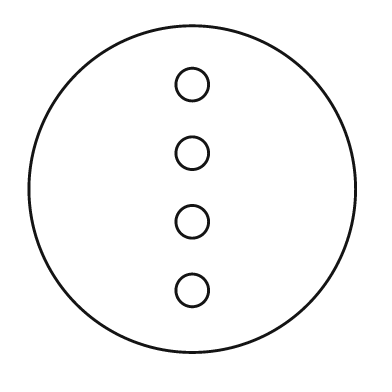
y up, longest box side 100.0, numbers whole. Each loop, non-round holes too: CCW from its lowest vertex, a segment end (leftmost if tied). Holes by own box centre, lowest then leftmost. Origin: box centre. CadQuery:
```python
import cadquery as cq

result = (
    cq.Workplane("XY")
    .moveTo(0.0, 0.0)
    .circle(50.0)
    .moveTo(0.0, -31.0)
    .circle(5.0)
    .moveTo(0.0, -10.0)
    .circle(5.0)
    .moveTo(0.0, 11.0)
    .circle(5.0)
    .moveTo(0.0, 32.0)
    .circle(5.0)
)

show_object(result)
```